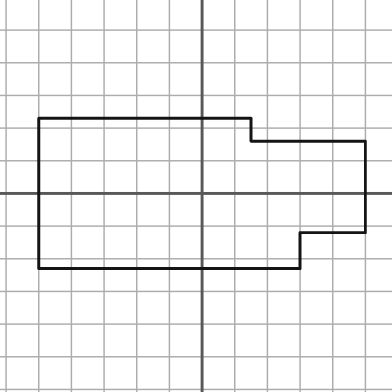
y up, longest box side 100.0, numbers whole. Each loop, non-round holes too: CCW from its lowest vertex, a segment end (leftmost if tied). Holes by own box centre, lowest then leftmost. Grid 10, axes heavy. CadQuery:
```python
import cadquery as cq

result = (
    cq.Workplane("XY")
    .moveTo(-50.0, -23.0)
    .lineTo(30.0, -23.0)
    .lineTo(30.0, -12.0)
    .lineTo(50.0, -12.0)
    .lineTo(50.0, 16.0)
    .lineTo(15.0, 16.0)
    .lineTo(15.0, 23.0)
    .lineTo(-50.0, 23.0)
    .close()
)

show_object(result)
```